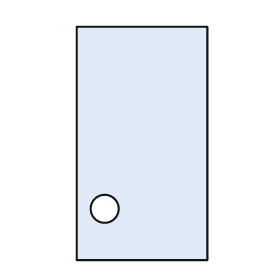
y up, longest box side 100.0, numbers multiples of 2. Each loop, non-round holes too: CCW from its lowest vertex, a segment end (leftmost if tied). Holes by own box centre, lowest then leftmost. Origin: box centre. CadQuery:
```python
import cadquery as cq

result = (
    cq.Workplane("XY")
    .moveTo(-28.0, -50.0)
    .lineTo(28.0, -50.0)
    .lineTo(28.0, 50.0)
    .lineTo(-28.0, 50.0)
    .close()
    .moveTo(-16.0, -28.0)
    .circle(6.0)
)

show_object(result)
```